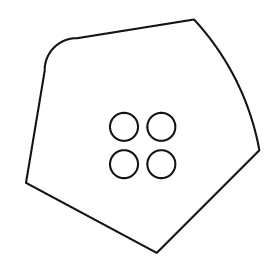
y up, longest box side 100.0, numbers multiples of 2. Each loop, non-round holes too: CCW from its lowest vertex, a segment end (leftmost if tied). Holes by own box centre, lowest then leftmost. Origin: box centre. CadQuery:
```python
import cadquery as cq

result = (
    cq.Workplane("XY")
    .moveTo(6.0, -50.0)
    .lineTo(50.0, -6.0)
    .threePointArc((40.0, 24.0), (22.0, 50.0))
    .lineTo(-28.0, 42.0)
    .threePointArc((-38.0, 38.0), (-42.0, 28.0))
    .lineTo(-50.0, -20.0)
    .close()
    .moveTo(-8.0, -12.0)
    .circle(6.0)
    .moveTo(8.0, -12.0)
    .circle(6.0)
    .moveTo(-8.0, 4.0)
    .circle(6.0)
    .moveTo(8.0, 4.0)
    .circle(6.0)
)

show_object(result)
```